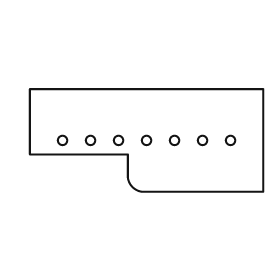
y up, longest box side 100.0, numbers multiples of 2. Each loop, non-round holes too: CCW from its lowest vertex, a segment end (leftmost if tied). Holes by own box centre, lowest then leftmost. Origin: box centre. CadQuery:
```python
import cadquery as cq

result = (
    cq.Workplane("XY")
    .moveTo(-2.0, -22.0)
    .lineTo(50.0, -22.0)
    .lineTo(50.0, 22.0)
    .lineTo(-50.0, 22.0)
    .lineTo(-50.0, -6.0)
    .lineTo(-8.0, -6.0)
    .lineTo(-8.0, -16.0)
    .threePointArc((-6.0, -20.0), (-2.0, -22.0))
    .close()
    .moveTo(-36.0, 0.0)
    .circle(2.0)
    .moveTo(-24.0, 0.0)
    .circle(2.0)
    .moveTo(-12.0, 0.0)
    .circle(2.0)
    .moveTo(0.0, 0.0)
    .circle(2.0)
    .moveTo(12.0, 0.0)
    .circle(2.0)
    .moveTo(24.0, 0.0)
    .circle(2.0)
    .moveTo(36.0, 0.0)
    .circle(2.0)
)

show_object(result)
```